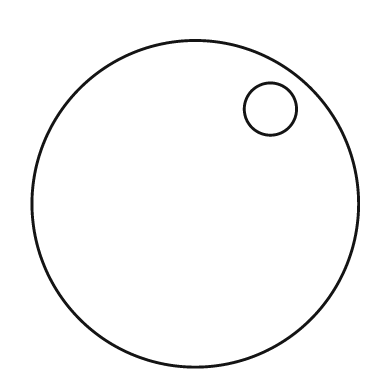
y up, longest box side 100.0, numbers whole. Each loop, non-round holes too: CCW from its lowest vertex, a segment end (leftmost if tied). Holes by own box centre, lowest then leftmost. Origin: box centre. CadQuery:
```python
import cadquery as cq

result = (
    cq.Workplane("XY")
    .moveTo(0.0, 0.0)
    .circle(50.0)
    .moveTo(23.0, 29.0)
    .circle(8.0)
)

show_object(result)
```